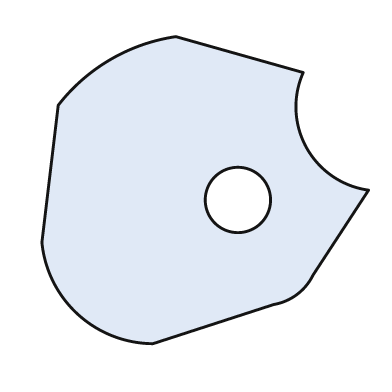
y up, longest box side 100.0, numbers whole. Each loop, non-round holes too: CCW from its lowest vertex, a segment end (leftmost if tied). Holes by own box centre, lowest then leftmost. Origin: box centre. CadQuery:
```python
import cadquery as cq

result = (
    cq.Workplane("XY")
    .moveTo(-16.0, -47.0)
    .lineTo(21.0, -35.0)
    .threePointArc((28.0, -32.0), (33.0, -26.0))
    .lineTo(50.0, 0.0)
    .threePointArc((31.0, 13.0), (30.0, 36.0))
    .lineTo(-9.0, 47.0)
    .threePointArc((-29.0, 40.0), (-45.0, 26.0))
    .lineTo(-50.0, -16.0)
    .threePointArc((-39.0, -38.0), (-16.0, -47.0))
    .close()
    .moveTo(10.0, -3.0)
    .circle(10.0)
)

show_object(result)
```